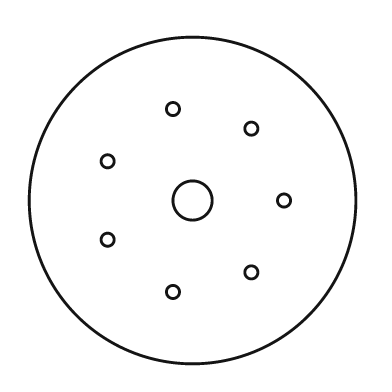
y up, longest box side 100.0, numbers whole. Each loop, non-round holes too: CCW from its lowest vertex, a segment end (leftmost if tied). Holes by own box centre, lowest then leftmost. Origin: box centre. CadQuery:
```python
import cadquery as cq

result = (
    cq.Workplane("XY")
    .moveTo(0.0, 0.0)
    .circle(50.0)
    .moveTo(-6.0, -28.0)
    .circle(2.0)
    .moveTo(18.0, -22.0)
    .circle(2.0)
    .moveTo(-26.0, -12.0)
    .circle(2.0)
    .moveTo(0.0, 0.0)
    .circle(6.0)
    .moveTo(28.0, 0.0)
    .circle(2.0)
    .moveTo(-26.0, 12.0)
    .circle(2.0)
    .moveTo(18.0, 22.0)
    .circle(2.0)
    .moveTo(-6.0, 28.0)
    .circle(2.0)
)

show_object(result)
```